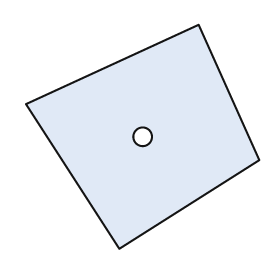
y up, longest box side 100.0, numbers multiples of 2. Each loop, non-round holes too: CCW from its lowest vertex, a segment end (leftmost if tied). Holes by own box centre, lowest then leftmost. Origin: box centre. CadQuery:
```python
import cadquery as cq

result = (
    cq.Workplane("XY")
    .moveTo(-10.0, -48.0)
    .lineTo(50.0, -10.0)
    .lineTo(24.0, 48.0)
    .lineTo(-50.0, 14.0)
    .close()
    .moveTo(0.0, 0.0)
    .circle(4.0)
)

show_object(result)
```